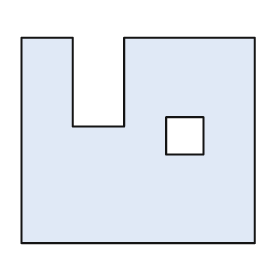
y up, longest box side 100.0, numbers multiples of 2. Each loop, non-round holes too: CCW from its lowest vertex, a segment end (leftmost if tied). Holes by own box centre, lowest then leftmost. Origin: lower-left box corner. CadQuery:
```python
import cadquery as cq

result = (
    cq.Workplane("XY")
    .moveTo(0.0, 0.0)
    .lineTo(100.0, 0.0)
    .lineTo(100.0, 88.0)
    .lineTo(44.0, 88.0)
    .lineTo(44.0, 50.0)
    .lineTo(22.0, 50.0)
    .lineTo(22.0, 88.0)
    .lineTo(0.0, 88.0)
    .close()
    .moveTo(62.0, 38.0)
    .lineTo(78.0, 38.0)
    .lineTo(78.0, 54.0)
    .lineTo(62.0, 54.0)
    .close()
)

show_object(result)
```